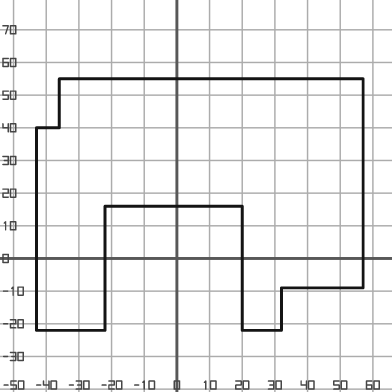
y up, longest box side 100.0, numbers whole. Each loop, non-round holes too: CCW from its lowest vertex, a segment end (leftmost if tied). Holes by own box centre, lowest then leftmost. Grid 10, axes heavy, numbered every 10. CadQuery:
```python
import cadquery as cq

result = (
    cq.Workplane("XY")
    .moveTo(-43.0, -22.0)
    .lineTo(-22.0, -22.0)
    .lineTo(-22.0, 16.0)
    .lineTo(20.0, 16.0)
    .lineTo(20.0, -22.0)
    .lineTo(32.0, -22.0)
    .lineTo(32.0, -9.0)
    .lineTo(57.0, -9.0)
    .lineTo(57.0, 55.0)
    .lineTo(-36.0, 55.0)
    .lineTo(-36.0, 40.0)
    .lineTo(-43.0, 40.0)
    .close()
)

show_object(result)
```